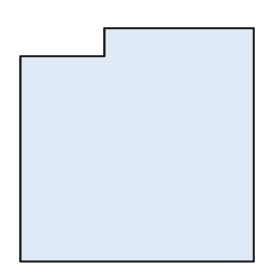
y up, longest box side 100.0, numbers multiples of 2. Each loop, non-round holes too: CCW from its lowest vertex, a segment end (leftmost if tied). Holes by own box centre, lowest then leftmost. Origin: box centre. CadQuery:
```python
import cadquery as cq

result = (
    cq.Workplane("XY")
    .moveTo(-50.0, -50.0)
    .lineTo(50.0, -50.0)
    .lineTo(50.0, 50.0)
    .lineTo(-14.0, 50.0)
    .lineTo(-14.0, 38.0)
    .lineTo(-50.0, 38.0)
    .close()
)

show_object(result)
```